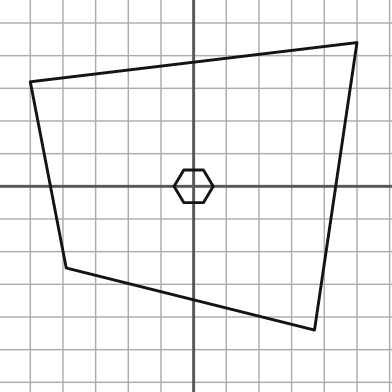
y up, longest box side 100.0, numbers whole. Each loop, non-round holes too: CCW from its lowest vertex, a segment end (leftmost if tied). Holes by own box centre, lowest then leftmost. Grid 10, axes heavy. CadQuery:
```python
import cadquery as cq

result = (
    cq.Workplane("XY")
    .moveTo(37.0, -44.0)
    .lineTo(50.0, 44.0)
    .lineTo(-50.0, 32.0)
    .lineTo(-39.0, -25.0)
    .close()
    .moveTo(-3.0, -5.0)
    .lineTo(3.0, -5.0)
    .lineTo(6.0, 0.0)
    .lineTo(3.0, 5.0)
    .lineTo(-3.0, 5.0)
    .lineTo(-6.0, 0.0)
    .close()
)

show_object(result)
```